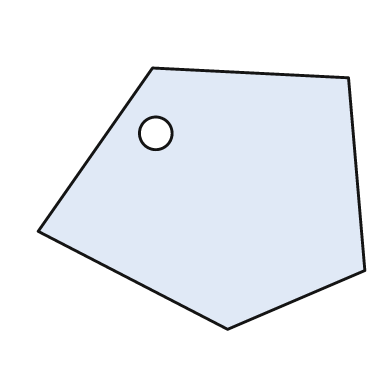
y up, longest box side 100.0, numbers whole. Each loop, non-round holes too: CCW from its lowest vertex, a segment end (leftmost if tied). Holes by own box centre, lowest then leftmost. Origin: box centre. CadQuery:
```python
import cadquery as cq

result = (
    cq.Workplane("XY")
    .moveTo(8.0, -40.0)
    .lineTo(50.0, -22.0)
    .lineTo(45.0, 37.0)
    .lineTo(-15.0, 40.0)
    .lineTo(-50.0, -10.0)
    .close()
    .moveTo(-14.0, 20.0)
    .circle(5.0)
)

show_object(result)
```